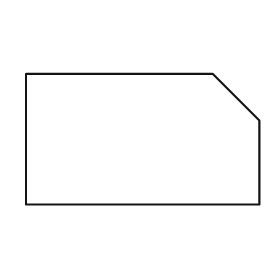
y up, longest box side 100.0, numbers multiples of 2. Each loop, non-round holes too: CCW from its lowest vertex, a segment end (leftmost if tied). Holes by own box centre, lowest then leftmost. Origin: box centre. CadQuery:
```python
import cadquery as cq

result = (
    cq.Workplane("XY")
    .moveTo(-50.0, -28.0)
    .lineTo(50.0, -28.0)
    .lineTo(50.0, 8.0)
    .lineTo(30.0, 28.0)
    .lineTo(-50.0, 28.0)
    .close()
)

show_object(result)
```